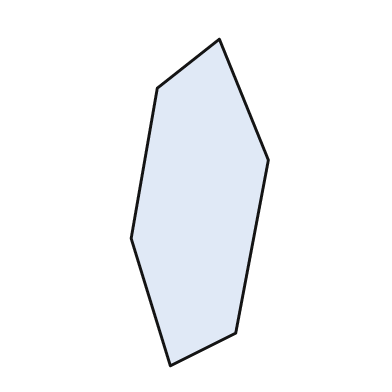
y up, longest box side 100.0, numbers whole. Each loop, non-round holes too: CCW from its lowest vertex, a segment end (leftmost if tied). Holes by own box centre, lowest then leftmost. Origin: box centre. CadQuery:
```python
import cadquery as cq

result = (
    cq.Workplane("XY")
    .moveTo(-9.0, -50.0)
    .lineTo(11.0, -40.0)
    .lineTo(21.0, 13.0)
    .lineTo(6.0, 50.0)
    .lineTo(-13.0, 35.0)
    .lineTo(-21.0, -11.0)
    .close()
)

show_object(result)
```